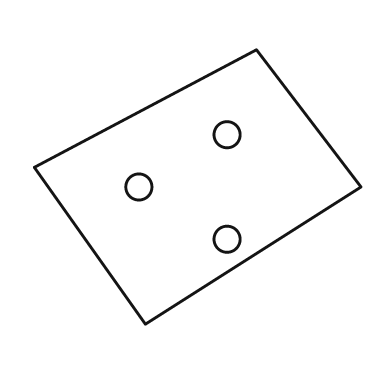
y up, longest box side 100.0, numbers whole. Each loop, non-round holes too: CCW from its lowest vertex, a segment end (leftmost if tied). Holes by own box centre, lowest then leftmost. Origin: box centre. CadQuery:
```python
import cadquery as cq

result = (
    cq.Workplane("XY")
    .moveTo(-16.0, -42.0)
    .lineTo(50.0, 0.0)
    .lineTo(18.0, 42.0)
    .lineTo(-50.0, 6.0)
    .close()
    .moveTo(9.0, -16.0)
    .circle(4.0)
    .moveTo(-18.0, 0.0)
    .circle(4.0)
    .moveTo(9.0, 16.0)
    .circle(4.0)
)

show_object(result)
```